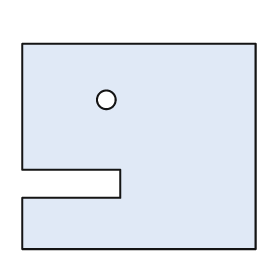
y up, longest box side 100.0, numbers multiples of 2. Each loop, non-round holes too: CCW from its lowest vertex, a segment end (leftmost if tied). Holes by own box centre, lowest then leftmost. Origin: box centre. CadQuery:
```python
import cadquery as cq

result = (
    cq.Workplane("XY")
    .moveTo(-50.0, -44.0)
    .lineTo(50.0, -44.0)
    .lineTo(50.0, 44.0)
    .lineTo(-50.0, 44.0)
    .lineTo(-50.0, -10.0)
    .lineTo(-8.0, -10.0)
    .lineTo(-8.0, -22.0)
    .lineTo(-50.0, -22.0)
    .close()
    .moveTo(-14.0, 20.0)
    .circle(4.0)
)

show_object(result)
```